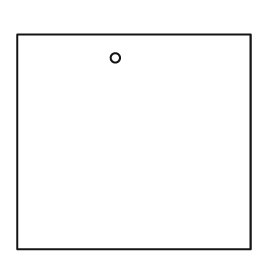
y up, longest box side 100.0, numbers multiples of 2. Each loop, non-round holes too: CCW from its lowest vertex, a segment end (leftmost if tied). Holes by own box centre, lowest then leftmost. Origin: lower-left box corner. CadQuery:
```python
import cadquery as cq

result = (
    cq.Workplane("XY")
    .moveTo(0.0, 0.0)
    .lineTo(100.0, 0.0)
    .lineTo(100.0, 92.0)
    .lineTo(0.0, 92.0)
    .close()
    .moveTo(42.0, 82.0)
    .circle(2.0)
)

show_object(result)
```